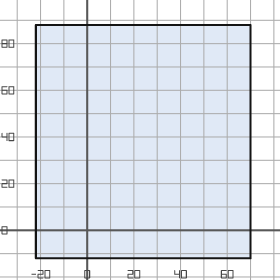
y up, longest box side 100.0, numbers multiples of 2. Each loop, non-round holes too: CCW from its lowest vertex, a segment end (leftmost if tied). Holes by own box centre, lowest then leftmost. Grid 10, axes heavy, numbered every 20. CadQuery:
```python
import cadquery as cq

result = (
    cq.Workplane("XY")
    .moveTo(-22.0, -12.0)
    .lineTo(70.0, -12.0)
    .lineTo(70.0, 88.0)
    .lineTo(-22.0, 88.0)
    .close()
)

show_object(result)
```